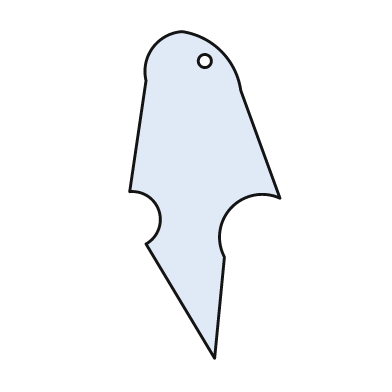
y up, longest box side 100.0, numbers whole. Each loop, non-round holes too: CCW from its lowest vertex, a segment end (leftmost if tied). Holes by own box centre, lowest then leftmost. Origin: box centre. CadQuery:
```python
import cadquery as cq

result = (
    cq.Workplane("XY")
    .moveTo(3.0, -50.0)
    .lineTo(6.0, -19.0)
    .threePointArc((8.0, -4.0), (23.0, -1.0))
    .lineTo(11.0, 32.0)
    .threePointArc((5.0, 44.0), (-7.0, 50.0))
    .threePointArc((-16.0, 45.0), (-18.0, 35.0))
    .lineTo(-23.0, 1.0)
    .threePointArc((-14.0, -5.0), (-18.0, -15.0))
    .close()
    .moveTo(0.0, 41.0)
    .circle(2.0)
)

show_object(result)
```